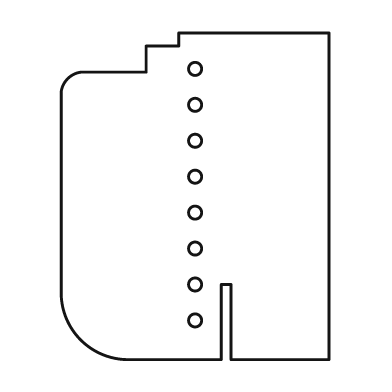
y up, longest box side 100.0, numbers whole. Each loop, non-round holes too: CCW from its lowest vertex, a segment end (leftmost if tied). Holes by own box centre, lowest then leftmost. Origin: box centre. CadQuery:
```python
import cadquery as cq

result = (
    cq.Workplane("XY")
    .moveTo(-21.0, -50.0)
    .lineTo(8.0, -50.0)
    .lineTo(8.0, -27.0)
    .lineTo(11.0, -27.0)
    .lineTo(11.0, -50.0)
    .lineTo(41.0, -50.0)
    .lineTo(41.0, 50.0)
    .lineTo(-5.0, 50.0)
    .lineTo(-5.0, 46.0)
    .lineTo(-15.0, 46.0)
    .lineTo(-15.0, 38.0)
    .lineTo(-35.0, 38.0)
    .threePointArc((-39.0, 36.0), (-41.0, 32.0))
    .lineTo(-41.0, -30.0)
    .threePointArc((-35.0, -44.0), (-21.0, -50.0))
    .close()
    .moveTo(0.0, -38.0)
    .circle(2.0)
    .moveTo(0.0, -27.0)
    .circle(2.0)
    .moveTo(0.0, -16.0)
    .circle(2.0)
    .moveTo(0.0, -5.0)
    .circle(2.0)
    .moveTo(0.0, 6.0)
    .circle(2.0)
    .moveTo(0.0, 17.0)
    .circle(2.0)
    .moveTo(0.0, 28.0)
    .circle(2.0)
    .moveTo(0.0, 39.0)
    .circle(2.0)
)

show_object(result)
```